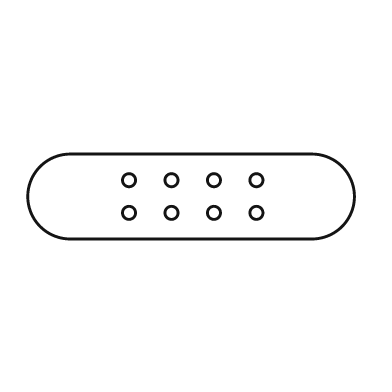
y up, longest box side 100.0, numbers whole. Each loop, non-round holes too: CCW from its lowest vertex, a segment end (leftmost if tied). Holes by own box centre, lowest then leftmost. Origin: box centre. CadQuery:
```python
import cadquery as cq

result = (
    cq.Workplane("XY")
    .moveTo(-37.0, -13.0)
    .lineTo(37.0, -13.0)
    .threePointArc((50.0, 0.0), (37.0, 13.0))
    .lineTo(-37.0, 13.0)
    .threePointArc((-50.0, 0.0), (-37.0, -13.0))
    .close()
    .moveTo(-19.0, -5.0)
    .circle(2.0)
    .moveTo(-6.0, -5.0)
    .circle(2.0)
    .moveTo(7.0, -5.0)
    .circle(2.0)
    .moveTo(20.0, -5.0)
    .circle(2.0)
    .moveTo(-19.0, 5.0)
    .circle(2.0)
    .moveTo(-6.0, 5.0)
    .circle(2.0)
    .moveTo(7.0, 5.0)
    .circle(2.0)
    .moveTo(20.0, 5.0)
    .circle(2.0)
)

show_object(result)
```